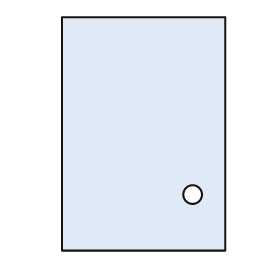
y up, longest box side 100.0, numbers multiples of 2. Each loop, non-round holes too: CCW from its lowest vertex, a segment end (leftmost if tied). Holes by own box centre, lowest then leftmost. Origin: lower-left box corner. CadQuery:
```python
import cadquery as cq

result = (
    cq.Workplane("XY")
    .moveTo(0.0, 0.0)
    .lineTo(70.0, 0.0)
    .lineTo(70.0, 100.0)
    .lineTo(0.0, 100.0)
    .close()
    .moveTo(56.0, 24.0)
    .circle(4.0)
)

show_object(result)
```